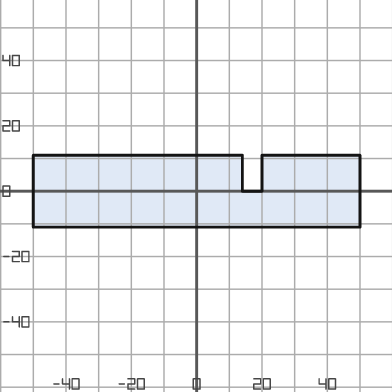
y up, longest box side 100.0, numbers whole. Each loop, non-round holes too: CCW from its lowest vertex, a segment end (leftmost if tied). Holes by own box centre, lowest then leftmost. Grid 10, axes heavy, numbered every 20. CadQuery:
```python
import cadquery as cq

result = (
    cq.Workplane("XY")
    .moveTo(-50.0, -11.0)
    .lineTo(50.0, -11.0)
    .lineTo(50.0, 11.0)
    .lineTo(20.0, 11.0)
    .lineTo(20.0, 0.0)
    .lineTo(14.0, 0.0)
    .lineTo(14.0, 11.0)
    .lineTo(-50.0, 11.0)
    .close()
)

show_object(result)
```